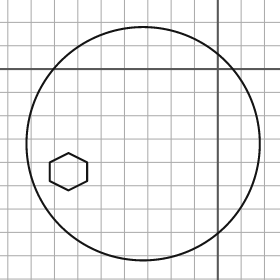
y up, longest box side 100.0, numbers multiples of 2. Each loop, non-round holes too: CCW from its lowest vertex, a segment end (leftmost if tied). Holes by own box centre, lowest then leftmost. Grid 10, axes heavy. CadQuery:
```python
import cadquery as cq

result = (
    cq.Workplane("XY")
    .moveTo(-32.0, -32.0)
    .circle(50.0)
    .moveTo(-64.0, -52.0)
    .lineTo(-56.0, -48.0)
    .lineTo(-56.0, -40.0)
    .lineTo(-64.0, -36.0)
    .lineTo(-72.0, -40.0)
    .lineTo(-72.0, -48.0)
    .close()
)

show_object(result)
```